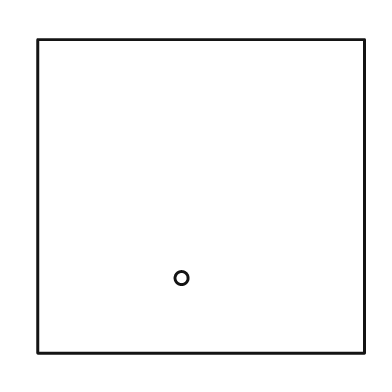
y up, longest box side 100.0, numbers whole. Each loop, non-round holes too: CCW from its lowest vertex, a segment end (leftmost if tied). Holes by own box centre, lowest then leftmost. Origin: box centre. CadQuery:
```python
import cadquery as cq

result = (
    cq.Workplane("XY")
    .moveTo(-50.0, -48.0)
    .lineTo(50.0, -48.0)
    .lineTo(50.0, 48.0)
    .lineTo(-50.0, 48.0)
    .close()
    .moveTo(-6.0, -25.0)
    .circle(2.0)
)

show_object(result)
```